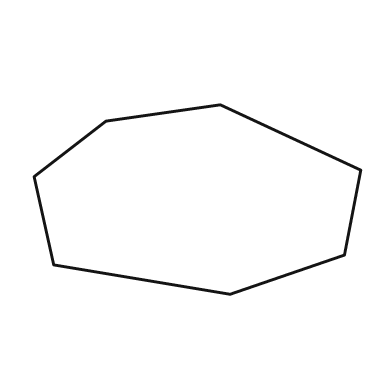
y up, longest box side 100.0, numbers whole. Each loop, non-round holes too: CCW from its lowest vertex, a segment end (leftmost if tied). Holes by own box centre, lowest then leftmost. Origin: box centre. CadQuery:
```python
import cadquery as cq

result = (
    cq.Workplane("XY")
    .moveTo(10.0, -29.0)
    .lineTo(45.0, -17.0)
    .lineTo(50.0, 9.0)
    .lineTo(7.0, 29.0)
    .lineTo(-28.0, 24.0)
    .lineTo(-50.0, 7.0)
    .lineTo(-44.0, -20.0)
    .close()
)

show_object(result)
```